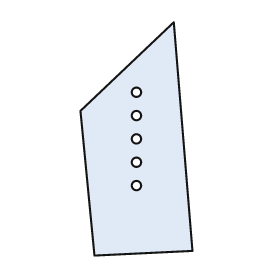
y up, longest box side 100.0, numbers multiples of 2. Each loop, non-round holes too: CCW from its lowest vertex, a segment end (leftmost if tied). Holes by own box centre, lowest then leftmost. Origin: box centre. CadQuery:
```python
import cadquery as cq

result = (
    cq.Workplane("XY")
    .moveTo(-18.0, -50.0)
    .lineTo(24.0, -48.0)
    .lineTo(16.0, 50.0)
    .lineTo(-24.0, 12.0)
    .close()
    .moveTo(0.0, -20.0)
    .circle(2.0)
    .moveTo(0.0, -10.0)
    .circle(2.0)
    .moveTo(0.0, 0.0)
    .circle(2.0)
    .moveTo(0.0, 10.0)
    .circle(2.0)
    .moveTo(0.0, 20.0)
    .circle(2.0)
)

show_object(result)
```